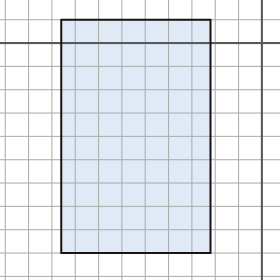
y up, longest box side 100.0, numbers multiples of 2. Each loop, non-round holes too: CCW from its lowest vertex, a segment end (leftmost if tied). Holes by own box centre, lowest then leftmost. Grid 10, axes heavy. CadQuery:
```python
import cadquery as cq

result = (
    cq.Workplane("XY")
    .moveTo(-86.0, -90.0)
    .lineTo(-22.0, -90.0)
    .lineTo(-22.0, 10.0)
    .lineTo(-86.0, 10.0)
    .close()
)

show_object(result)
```